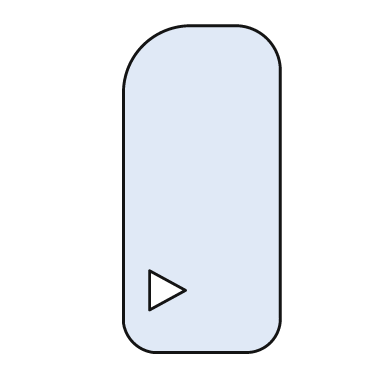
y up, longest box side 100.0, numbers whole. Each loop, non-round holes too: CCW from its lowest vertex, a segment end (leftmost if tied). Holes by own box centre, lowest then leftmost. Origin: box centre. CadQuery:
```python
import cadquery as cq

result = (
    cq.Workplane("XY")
    .moveTo(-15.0, -50.0)
    .lineTo(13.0, -50.0)
    .threePointArc((21.0, -47.0), (24.0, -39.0))
    .lineTo(24.0, 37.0)
    .threePointArc((20.0, 46.0), (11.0, 50.0))
    .lineTo(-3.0, 50.0)
    .threePointArc((-18.0, 44.0), (-24.0, 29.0))
    .lineTo(-24.0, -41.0)
    .threePointArc((-21.0, -47.0), (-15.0, -50.0))
    .close()
    .moveTo(-16.0, -37.0)
    .lineTo(-5.0, -31.0)
    .lineTo(-16.0, -25.0)
    .close()
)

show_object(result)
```